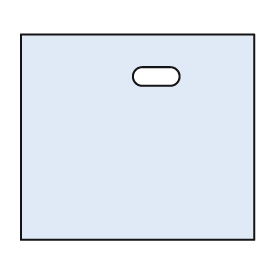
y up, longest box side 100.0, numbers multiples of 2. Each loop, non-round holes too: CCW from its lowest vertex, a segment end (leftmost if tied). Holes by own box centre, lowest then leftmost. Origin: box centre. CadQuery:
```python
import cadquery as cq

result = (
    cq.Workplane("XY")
    .moveTo(-50.0, -44.0)
    .lineTo(50.0, -44.0)
    .lineTo(50.0, 44.0)
    .lineTo(-50.0, 44.0)
    .close()
    .moveTo(2.0, 22.0)
    .lineTo(14.0, 22.0)
    .threePointArc((18.0, 26.0), (14.0, 30.0))
    .lineTo(2.0, 30.0)
    .threePointArc((-2.0, 26.0), (2.0, 22.0))
    .close()
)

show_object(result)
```